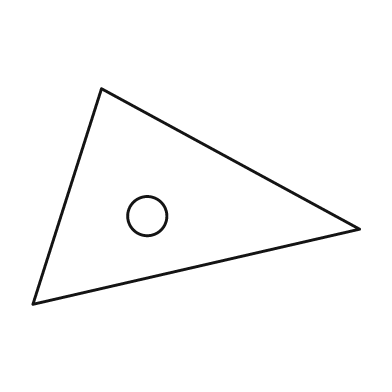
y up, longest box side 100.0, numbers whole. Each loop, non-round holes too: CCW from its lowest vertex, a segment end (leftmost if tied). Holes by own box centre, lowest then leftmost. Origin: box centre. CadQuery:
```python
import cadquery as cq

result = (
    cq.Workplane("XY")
    .moveTo(-50.0, -33.0)
    .lineTo(50.0, -10.0)
    .lineTo(-29.0, 33.0)
    .close()
    .moveTo(-15.0, -6.0)
    .circle(6.0)
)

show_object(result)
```